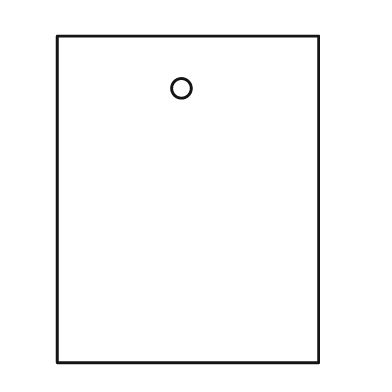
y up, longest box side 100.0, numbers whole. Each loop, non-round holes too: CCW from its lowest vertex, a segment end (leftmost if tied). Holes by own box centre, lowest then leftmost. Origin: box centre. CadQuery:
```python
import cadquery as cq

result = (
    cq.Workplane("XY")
    .moveTo(-40.0, -50.0)
    .lineTo(40.0, -50.0)
    .lineTo(40.0, 50.0)
    .lineTo(-40.0, 50.0)
    .close()
    .moveTo(-2.0, 34.0)
    .circle(3.0)
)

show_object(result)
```